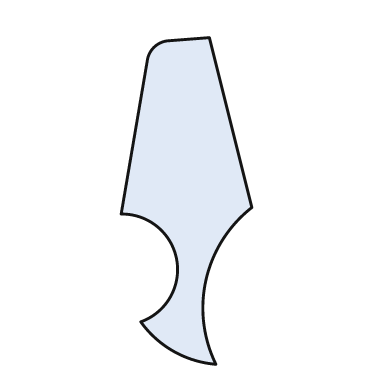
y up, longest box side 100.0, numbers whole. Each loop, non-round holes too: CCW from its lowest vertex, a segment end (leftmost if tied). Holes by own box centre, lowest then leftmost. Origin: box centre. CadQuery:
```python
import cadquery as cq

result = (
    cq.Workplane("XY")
    .moveTo(9.0, -50.0)
    .threePointArc((6.0, -24.0), (20.0, -2.0))
    .lineTo(7.0, 50.0)
    .lineTo(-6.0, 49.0)
    .threePointArc((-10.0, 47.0), (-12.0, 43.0))
    .lineTo(-20.0, -4.0)
    .threePointArc((-3.0, -18.0), (-14.0, -37.0))
    .threePointArc((-4.0, -46.0), (9.0, -50.0))
    .close()
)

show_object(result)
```